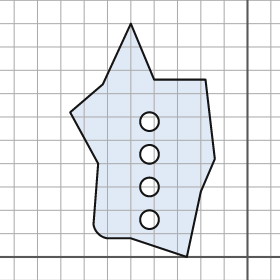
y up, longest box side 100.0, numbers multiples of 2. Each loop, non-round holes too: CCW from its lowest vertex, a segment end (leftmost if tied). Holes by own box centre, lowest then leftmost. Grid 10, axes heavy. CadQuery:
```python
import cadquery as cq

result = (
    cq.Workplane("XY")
    .moveTo(-26.0, 0.0)
    .lineTo(-20.0, 28.0)
    .lineTo(-14.0, 42.0)
    .lineTo(-18.0, 76.0)
    .lineTo(-40.0, 76.0)
    .lineTo(-50.0, 100.0)
    .lineTo(-62.0, 74.0)
    .lineTo(-76.0, 62.0)
    .lineTo(-64.0, 40.0)
    .lineTo(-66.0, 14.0)
    .threePointArc((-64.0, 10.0), (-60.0, 8.0))
    .lineTo(-50.0, 8.0)
    .close()
    .moveTo(-42.0, 16.0)
    .circle(4.0)
    .moveTo(-42.0, 30.0)
    .circle(4.0)
    .moveTo(-42.0, 44.0)
    .circle(4.0)
    .moveTo(-42.0, 58.0)
    .circle(4.0)
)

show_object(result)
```